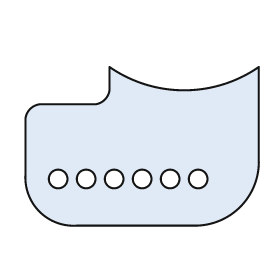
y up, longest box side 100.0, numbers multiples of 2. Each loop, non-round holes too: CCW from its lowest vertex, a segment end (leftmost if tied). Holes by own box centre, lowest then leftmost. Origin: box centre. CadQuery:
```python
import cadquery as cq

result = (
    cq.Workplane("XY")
    .moveTo(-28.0, -34.0)
    .lineTo(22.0, -34.0)
    .threePointArc((42.0, -26.0), (50.0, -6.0))
    .lineTo(50.0, 34.0)
    .threePointArc((18.0, 24.0), (-14.0, 34.0))
    .lineTo(-14.0, 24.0)
    .threePointArc((-16.0, 20.0), (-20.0, 18.0))
    .lineTo(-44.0, 18.0)
    .threePointArc((-48.0, 16.0), (-50.0, 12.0))
    .lineTo(-50.0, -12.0)
    .threePointArc((-44.0, -28.0), (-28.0, -34.0))
    .close()
    .moveTo(-36.0, -14.0)
    .circle(4.0)
    .moveTo(-24.0, -14.0)
    .circle(4.0)
    .moveTo(-12.0, -14.0)
    .circle(4.0)
    .moveTo(0.0, -14.0)
    .circle(4.0)
    .moveTo(12.0, -14.0)
    .circle(4.0)
    .moveTo(24.0, -14.0)
    .circle(4.0)
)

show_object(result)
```